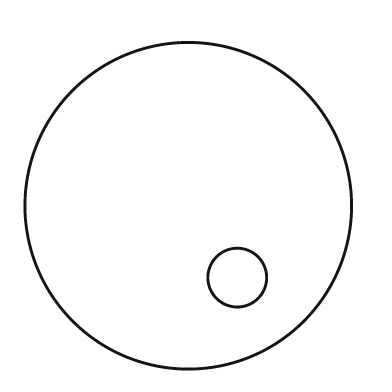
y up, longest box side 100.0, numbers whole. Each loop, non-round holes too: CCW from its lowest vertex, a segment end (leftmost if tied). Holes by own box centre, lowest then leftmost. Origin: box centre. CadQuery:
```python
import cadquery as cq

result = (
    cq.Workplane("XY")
    .moveTo(0.0, 0.0)
    .circle(50.0)
    .moveTo(15.0, -22.0)
    .circle(9.0)
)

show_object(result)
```